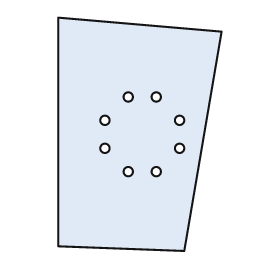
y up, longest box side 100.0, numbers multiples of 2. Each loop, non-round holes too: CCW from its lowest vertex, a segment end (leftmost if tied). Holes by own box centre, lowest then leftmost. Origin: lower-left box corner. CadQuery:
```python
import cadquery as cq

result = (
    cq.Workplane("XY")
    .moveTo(54.0, 0.0)
    .lineTo(70.0, 94.0)
    .lineTo(0.0, 100.0)
    .lineTo(0.0, 2.0)
    .close()
    .moveTo(30.0, 34.0)
    .circle(2.0)
    .moveTo(42.0, 34.0)
    .circle(2.0)
    .moveTo(20.0, 44.0)
    .circle(2.0)
    .moveTo(52.0, 44.0)
    .circle(2.0)
    .moveTo(20.0, 56.0)
    .circle(2.0)
    .moveTo(52.0, 56.0)
    .circle(2.0)
    .moveTo(30.0, 66.0)
    .circle(2.0)
    .moveTo(42.0, 66.0)
    .circle(2.0)
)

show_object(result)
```